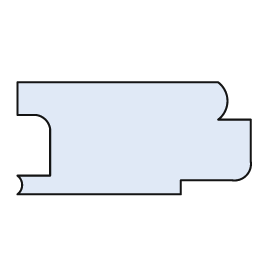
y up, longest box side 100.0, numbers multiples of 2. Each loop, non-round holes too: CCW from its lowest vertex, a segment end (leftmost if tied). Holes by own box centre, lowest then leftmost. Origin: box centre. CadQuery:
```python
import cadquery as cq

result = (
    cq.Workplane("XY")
    .moveTo(-50.0, -24.0)
    .lineTo(20.0, -24.0)
    .lineTo(20.0, -18.0)
    .lineTo(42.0, -18.0)
    .threePointArc((48.0, -16.0), (50.0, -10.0))
    .lineTo(50.0, 8.0)
    .lineTo(36.0, 8.0)
    .threePointArc((40.0, 16.0), (36.0, 24.0))
    .lineTo(-50.0, 24.0)
    .lineTo(-50.0, 10.0)
    .lineTo(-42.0, 10.0)
    .threePointArc((-38.0, 8.0), (-36.0, 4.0))
    .lineTo(-36.0, -16.0)
    .lineTo(-50.0, -16.0)
    .threePointArc((-48.0, -20.0), (-50.0, -24.0))
    .close()
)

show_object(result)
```